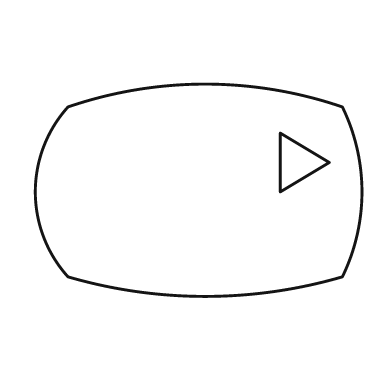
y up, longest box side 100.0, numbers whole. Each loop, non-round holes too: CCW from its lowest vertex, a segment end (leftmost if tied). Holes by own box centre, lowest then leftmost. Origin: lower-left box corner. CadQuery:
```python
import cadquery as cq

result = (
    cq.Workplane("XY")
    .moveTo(10.0, 6.0)
    .threePointArc((52.0, 0.0), (94.0, 6.0))
    .threePointArc((100.0, 32.0), (94.0, 58.0))
    .threePointArc((52.0, 65.0), (10.0, 58.0))
    .threePointArc((0.0, 32.0), (10.0, 6.0))
    .close()
    .moveTo(75.0, 32.0)
    .lineTo(90.0, 41.0)
    .lineTo(75.0, 50.0)
    .close()
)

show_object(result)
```